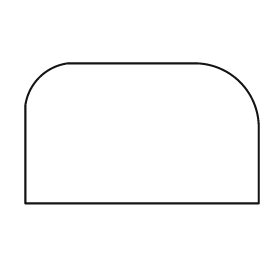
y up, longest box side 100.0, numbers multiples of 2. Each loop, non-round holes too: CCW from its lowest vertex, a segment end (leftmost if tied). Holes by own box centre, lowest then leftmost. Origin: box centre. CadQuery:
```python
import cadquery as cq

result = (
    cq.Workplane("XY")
    .moveTo(-50.0, -30.0)
    .lineTo(50.0, -30.0)
    .lineTo(50.0, 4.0)
    .threePointArc((42.0, 22.0), (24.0, 30.0))
    .lineTo(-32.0, 30.0)
    .threePointArc((-44.0, 24.0), (-50.0, 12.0))
    .close()
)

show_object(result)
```